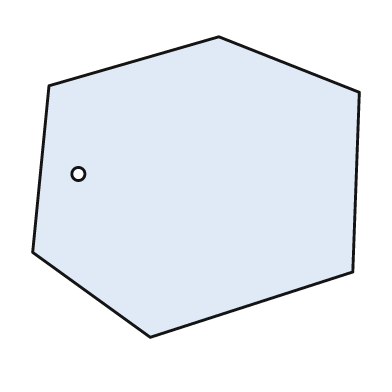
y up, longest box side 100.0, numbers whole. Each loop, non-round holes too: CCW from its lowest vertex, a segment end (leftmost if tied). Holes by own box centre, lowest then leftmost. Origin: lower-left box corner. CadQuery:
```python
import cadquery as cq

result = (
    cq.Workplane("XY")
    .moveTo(36.0, 0.0)
    .lineTo(98.0, 20.0)
    .lineTo(100.0, 75.0)
    .lineTo(57.0, 92.0)
    .lineTo(5.0, 77.0)
    .lineTo(0.0, 26.0)
    .close()
    .moveTo(14.0, 50.0)
    .circle(2.0)
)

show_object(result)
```